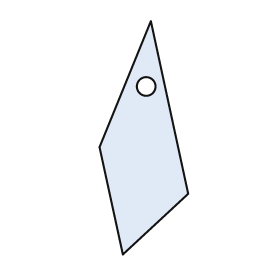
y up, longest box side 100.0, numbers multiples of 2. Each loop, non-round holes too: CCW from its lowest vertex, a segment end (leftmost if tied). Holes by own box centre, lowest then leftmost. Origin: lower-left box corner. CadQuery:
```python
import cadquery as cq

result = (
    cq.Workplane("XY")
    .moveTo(10.0, 0.0)
    .lineTo(38.0, 26.0)
    .lineTo(22.0, 100.0)
    .lineTo(0.0, 46.0)
    .close()
    .moveTo(20.0, 72.0)
    .circle(4.0)
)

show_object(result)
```